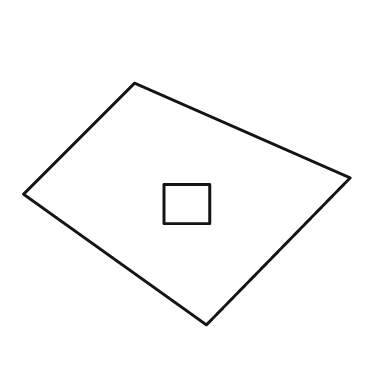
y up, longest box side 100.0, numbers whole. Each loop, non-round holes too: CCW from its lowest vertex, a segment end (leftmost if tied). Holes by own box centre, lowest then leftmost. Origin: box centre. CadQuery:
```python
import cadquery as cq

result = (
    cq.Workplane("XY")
    .moveTo(6.0, -37.0)
    .lineTo(50.0, 8.0)
    .lineTo(-16.0, 37.0)
    .lineTo(-50.0, 3.0)
    .close()
    .moveTo(-7.0, -6.0)
    .lineTo(7.0, -6.0)
    .lineTo(7.0, 6.0)
    .lineTo(-7.0, 6.0)
    .close()
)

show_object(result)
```